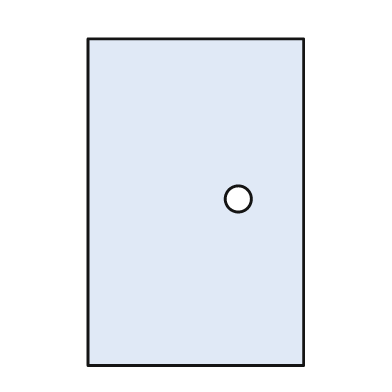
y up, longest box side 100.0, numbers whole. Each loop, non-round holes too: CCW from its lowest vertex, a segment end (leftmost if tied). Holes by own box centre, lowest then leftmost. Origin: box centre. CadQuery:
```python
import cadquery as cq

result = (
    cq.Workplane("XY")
    .moveTo(-33.0, -50.0)
    .lineTo(33.0, -50.0)
    .lineTo(33.0, 50.0)
    .lineTo(-33.0, 50.0)
    .close()
    .moveTo(13.0, 1.0)
    .circle(4.0)
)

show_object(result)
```